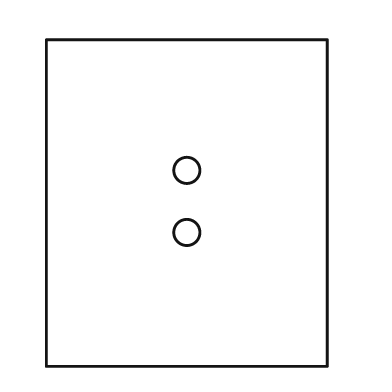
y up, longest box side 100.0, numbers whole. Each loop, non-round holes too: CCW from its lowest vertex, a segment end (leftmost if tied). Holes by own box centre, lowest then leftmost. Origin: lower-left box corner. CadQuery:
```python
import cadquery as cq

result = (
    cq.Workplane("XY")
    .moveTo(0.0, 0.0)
    .lineTo(86.0, 0.0)
    .lineTo(86.0, 100.0)
    .lineTo(0.0, 100.0)
    .close()
    .moveTo(43.0, 41.0)
    .circle(4.0)
    .moveTo(43.0, 60.0)
    .circle(4.0)
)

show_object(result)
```